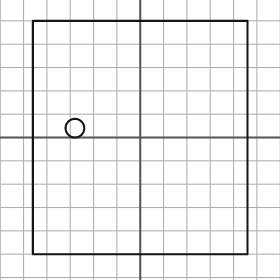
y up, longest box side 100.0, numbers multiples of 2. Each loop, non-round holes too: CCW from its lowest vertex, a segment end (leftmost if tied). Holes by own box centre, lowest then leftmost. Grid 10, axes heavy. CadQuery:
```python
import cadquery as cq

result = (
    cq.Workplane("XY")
    .moveTo(-46.0, -50.0)
    .lineTo(46.0, -50.0)
    .lineTo(46.0, 50.0)
    .lineTo(-46.0, 50.0)
    .close()
    .moveTo(-28.0, 4.0)
    .circle(4.0)
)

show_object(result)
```